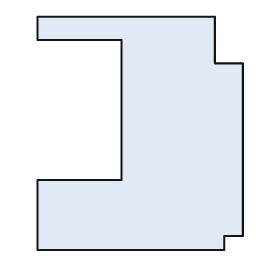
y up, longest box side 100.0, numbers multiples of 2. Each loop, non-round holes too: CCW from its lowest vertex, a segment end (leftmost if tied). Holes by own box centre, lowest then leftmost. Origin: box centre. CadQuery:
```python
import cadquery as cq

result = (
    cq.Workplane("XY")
    .moveTo(-44.0, -50.0)
    .lineTo(36.0, -50.0)
    .lineTo(36.0, -44.0)
    .lineTo(44.0, -44.0)
    .lineTo(44.0, 30.0)
    .lineTo(32.0, 30.0)
    .lineTo(32.0, 50.0)
    .lineTo(-44.0, 50.0)
    .lineTo(-44.0, 40.0)
    .lineTo(-8.0, 40.0)
    .lineTo(-8.0, -20.0)
    .lineTo(-44.0, -20.0)
    .close()
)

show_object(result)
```